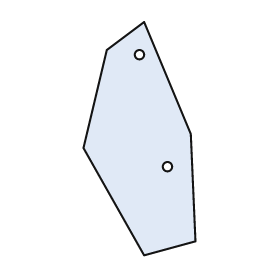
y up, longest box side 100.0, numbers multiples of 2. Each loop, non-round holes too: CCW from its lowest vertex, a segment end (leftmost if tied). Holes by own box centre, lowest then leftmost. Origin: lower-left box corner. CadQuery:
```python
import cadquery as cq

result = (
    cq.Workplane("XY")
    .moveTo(26.0, 0.0)
    .lineTo(48.0, 6.0)
    .lineTo(46.0, 52.0)
    .lineTo(26.0, 100.0)
    .lineTo(10.0, 88.0)
    .lineTo(0.0, 46.0)
    .close()
    .moveTo(36.0, 38.0)
    .circle(2.0)
    .moveTo(24.0, 86.0)
    .circle(2.0)
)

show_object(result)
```